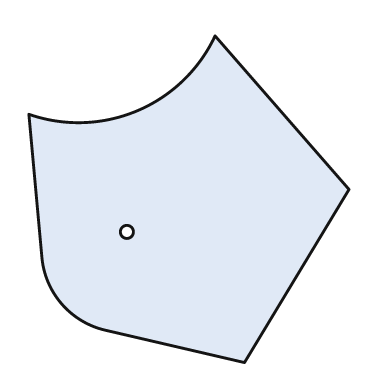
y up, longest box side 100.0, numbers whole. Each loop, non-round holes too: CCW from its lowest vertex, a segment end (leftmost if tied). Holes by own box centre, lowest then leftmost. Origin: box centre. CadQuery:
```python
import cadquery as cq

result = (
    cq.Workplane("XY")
    .moveTo(17.0, -50.0)
    .lineTo(49.0, 3.0)
    .lineTo(8.0, 50.0)
    .threePointArc((-16.0, 27.0), (-49.0, 26.0))
    .lineTo(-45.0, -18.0)
    .threePointArc((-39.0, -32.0), (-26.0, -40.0))
    .close()
    .moveTo(-19.0, -10.0)
    .circle(2.0)
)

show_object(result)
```